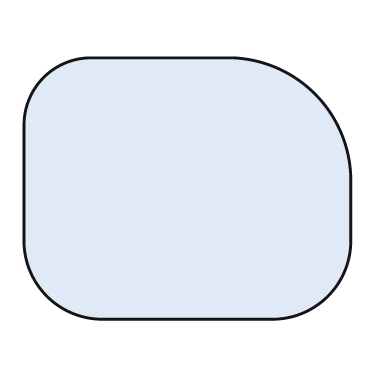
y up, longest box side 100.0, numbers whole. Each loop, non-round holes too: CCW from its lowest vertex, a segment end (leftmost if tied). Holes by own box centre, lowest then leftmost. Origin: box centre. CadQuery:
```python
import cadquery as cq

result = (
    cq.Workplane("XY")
    .moveTo(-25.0, -40.0)
    .lineTo(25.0, -40.0)
    .threePointArc((43.0, -33.0), (50.0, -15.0))
    .lineTo(50.0, 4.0)
    .threePointArc((39.0, 29.0), (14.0, 40.0))
    .lineTo(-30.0, 40.0)
    .threePointArc((-44.0, 34.0), (-50.0, 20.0))
    .lineTo(-50.0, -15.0)
    .threePointArc((-43.0, -33.0), (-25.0, -40.0))
    .close()
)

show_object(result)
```